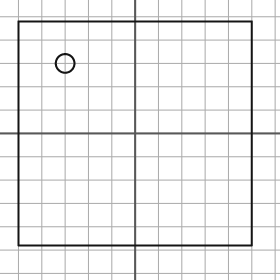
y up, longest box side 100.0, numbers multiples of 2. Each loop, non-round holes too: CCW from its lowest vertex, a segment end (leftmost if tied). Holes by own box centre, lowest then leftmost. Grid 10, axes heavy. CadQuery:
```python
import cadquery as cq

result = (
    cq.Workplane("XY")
    .moveTo(-50.0, -48.0)
    .lineTo(50.0, -48.0)
    .lineTo(50.0, 48.0)
    .lineTo(-50.0, 48.0)
    .close()
    .moveTo(-30.0, 30.0)
    .circle(4.0)
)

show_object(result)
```